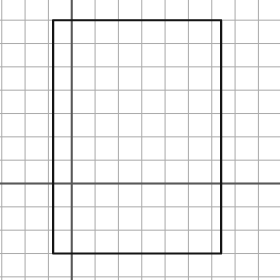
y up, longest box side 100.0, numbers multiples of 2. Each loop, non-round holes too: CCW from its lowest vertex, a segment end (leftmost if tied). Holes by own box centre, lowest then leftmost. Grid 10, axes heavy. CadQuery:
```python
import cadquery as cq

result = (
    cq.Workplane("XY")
    .moveTo(-8.0, -30.0)
    .lineTo(64.0, -30.0)
    .lineTo(64.0, 70.0)
    .lineTo(-8.0, 70.0)
    .close()
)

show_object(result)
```